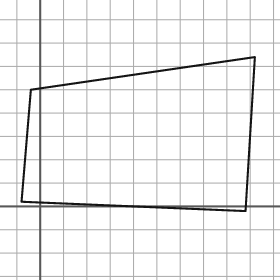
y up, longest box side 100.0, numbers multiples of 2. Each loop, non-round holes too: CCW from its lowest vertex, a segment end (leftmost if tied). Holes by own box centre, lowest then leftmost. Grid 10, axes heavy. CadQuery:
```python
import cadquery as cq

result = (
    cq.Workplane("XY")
    .moveTo(88.0, -2.0)
    .lineTo(92.0, 64.0)
    .lineTo(-4.0, 50.0)
    .lineTo(-8.0, 2.0)
    .close()
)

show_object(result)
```